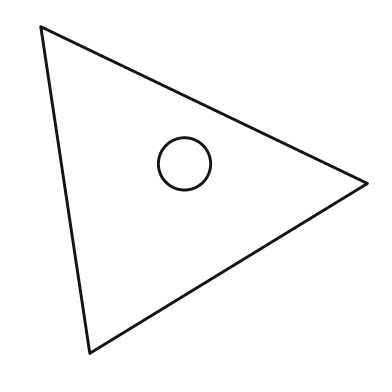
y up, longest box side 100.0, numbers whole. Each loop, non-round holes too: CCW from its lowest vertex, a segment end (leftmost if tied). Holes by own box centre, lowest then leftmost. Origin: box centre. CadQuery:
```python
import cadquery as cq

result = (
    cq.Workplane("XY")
    .moveTo(-35.0, -50.0)
    .lineTo(50.0, 2.0)
    .lineTo(-50.0, 50.0)
    .close()
    .moveTo(-6.0, 8.0)
    .circle(8.0)
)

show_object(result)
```